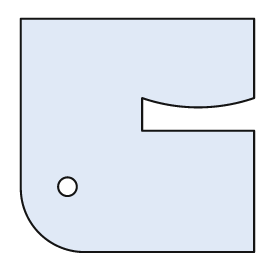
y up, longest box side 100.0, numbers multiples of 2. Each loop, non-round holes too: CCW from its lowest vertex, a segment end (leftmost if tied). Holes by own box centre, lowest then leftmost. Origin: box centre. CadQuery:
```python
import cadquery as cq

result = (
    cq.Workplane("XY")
    .moveTo(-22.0, -50.0)
    .lineTo(50.0, -50.0)
    .lineTo(50.0, 2.0)
    .lineTo(2.0, 2.0)
    .lineTo(2.0, 16.0)
    .threePointArc((26.0, 12.0), (50.0, 16.0))
    .lineTo(50.0, 50.0)
    .lineTo(-50.0, 50.0)
    .lineTo(-50.0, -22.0)
    .threePointArc((-42.0, -42.0), (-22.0, -50.0))
    .close()
    .moveTo(-30.0, -22.0)
    .circle(4.0)
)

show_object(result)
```